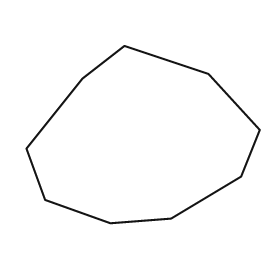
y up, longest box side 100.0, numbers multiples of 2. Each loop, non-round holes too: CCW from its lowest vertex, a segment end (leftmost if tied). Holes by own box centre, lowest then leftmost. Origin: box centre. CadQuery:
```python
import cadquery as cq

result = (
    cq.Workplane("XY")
    .moveTo(-14.0, -38.0)
    .lineTo(12.0, -36.0)
    .lineTo(42.0, -18.0)
    .lineTo(50.0, 2.0)
    .lineTo(28.0, 26.0)
    .lineTo(-8.0, 38.0)
    .lineTo(-26.0, 24.0)
    .lineTo(-50.0, -6.0)
    .lineTo(-42.0, -28.0)
    .close()
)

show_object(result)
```